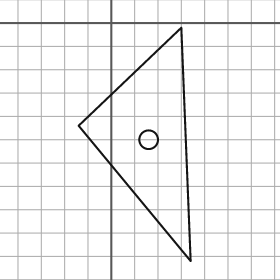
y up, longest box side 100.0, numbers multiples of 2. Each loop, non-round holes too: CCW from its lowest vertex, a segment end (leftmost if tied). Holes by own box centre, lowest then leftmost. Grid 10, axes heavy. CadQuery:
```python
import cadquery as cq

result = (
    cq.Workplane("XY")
    .moveTo(34.0, -102.0)
    .lineTo(30.0, -2.0)
    .lineTo(-14.0, -44.0)
    .close()
    .moveTo(16.0, -50.0)
    .circle(4.0)
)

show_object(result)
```